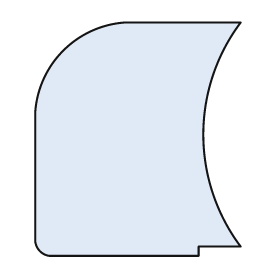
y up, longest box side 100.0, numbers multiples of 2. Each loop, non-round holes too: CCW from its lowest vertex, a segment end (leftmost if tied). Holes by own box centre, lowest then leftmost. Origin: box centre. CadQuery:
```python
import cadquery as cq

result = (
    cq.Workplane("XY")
    .moveTo(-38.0, -50.0)
    .lineTo(26.0, -50.0)
    .lineTo(26.0, -46.0)
    .lineTo(44.0, -46.0)
    .threePointArc((28.0, 2.0), (44.0, 50.0))
    .lineTo(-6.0, 50.0)
    .threePointArc((-32.0, 38.0), (-44.0, 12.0))
    .lineTo(-44.0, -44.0)
    .threePointArc((-42.0, -48.0), (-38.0, -50.0))
    .close()
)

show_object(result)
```